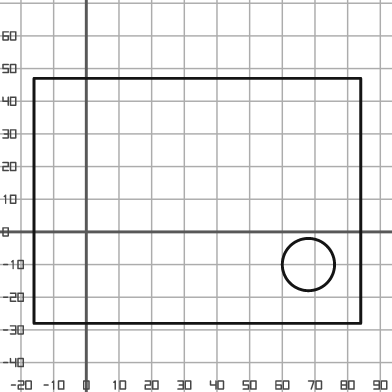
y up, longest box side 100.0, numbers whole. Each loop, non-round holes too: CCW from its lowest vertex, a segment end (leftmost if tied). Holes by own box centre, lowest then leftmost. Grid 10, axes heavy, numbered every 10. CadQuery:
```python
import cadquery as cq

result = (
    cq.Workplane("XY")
    .moveTo(-16.0, -28.0)
    .lineTo(84.0, -28.0)
    .lineTo(84.0, 47.0)
    .lineTo(-16.0, 47.0)
    .close()
    .moveTo(68.0, -10.0)
    .circle(8.0)
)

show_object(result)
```